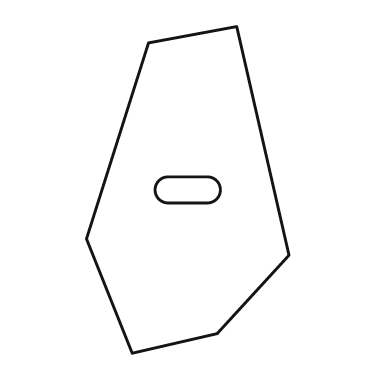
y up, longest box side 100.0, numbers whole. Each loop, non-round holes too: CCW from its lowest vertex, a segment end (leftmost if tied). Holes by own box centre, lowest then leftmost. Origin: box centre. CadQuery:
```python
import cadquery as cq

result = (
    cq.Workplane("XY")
    .moveTo(-17.0, -50.0)
    .lineTo(9.0, -44.0)
    .lineTo(31.0, -20.0)
    .lineTo(15.0, 50.0)
    .lineTo(-12.0, 45.0)
    .lineTo(-31.0, -15.0)
    .close()
    .moveTo(-6.0, -4.0)
    .lineTo(6.0, -4.0)
    .threePointArc((10.0, 0.0), (6.0, 4.0))
    .lineTo(-6.0, 4.0)
    .threePointArc((-10.0, 0.0), (-6.0, -4.0))
    .close()
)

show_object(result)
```